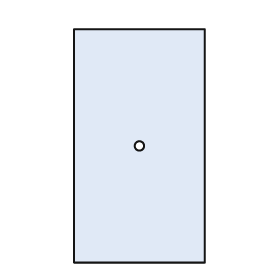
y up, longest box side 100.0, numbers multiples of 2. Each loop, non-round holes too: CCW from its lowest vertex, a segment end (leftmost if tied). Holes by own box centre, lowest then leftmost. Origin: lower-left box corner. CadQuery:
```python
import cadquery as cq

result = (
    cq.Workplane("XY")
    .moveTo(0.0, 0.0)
    .lineTo(56.0, 0.0)
    .lineTo(56.0, 100.0)
    .lineTo(0.0, 100.0)
    .close()
    .moveTo(28.0, 50.0)
    .circle(2.0)
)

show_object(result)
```